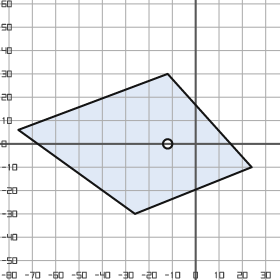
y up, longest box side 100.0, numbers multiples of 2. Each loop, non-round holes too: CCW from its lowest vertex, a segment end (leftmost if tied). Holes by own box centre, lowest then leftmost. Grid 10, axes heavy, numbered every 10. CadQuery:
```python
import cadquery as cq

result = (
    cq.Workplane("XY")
    .moveTo(-26.0, -30.0)
    .lineTo(24.0, -10.0)
    .lineTo(-12.0, 30.0)
    .lineTo(-76.0, 6.0)
    .close()
    .moveTo(-12.0, 0.0)
    .circle(2.0)
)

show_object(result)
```